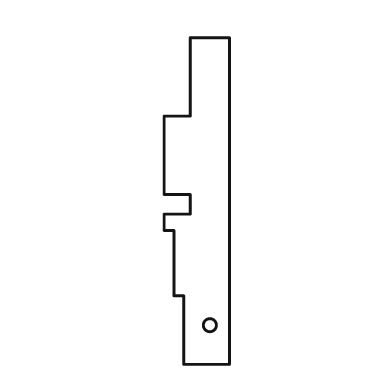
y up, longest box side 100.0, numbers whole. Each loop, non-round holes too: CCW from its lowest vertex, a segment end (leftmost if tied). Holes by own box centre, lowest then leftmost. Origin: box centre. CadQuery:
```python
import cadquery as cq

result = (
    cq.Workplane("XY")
    .moveTo(-4.0, -50.0)
    .lineTo(10.0, -50.0)
    .lineTo(10.0, 50.0)
    .lineTo(-2.0, 50.0)
    .lineTo(-2.0, 26.0)
    .lineTo(-10.0, 26.0)
    .lineTo(-10.0, 2.0)
    .lineTo(-2.0, 2.0)
    .lineTo(-2.0, -4.0)
    .lineTo(-10.0, -4.0)
    .lineTo(-10.0, -9.0)
    .lineTo(-7.0, -9.0)
    .lineTo(-7.0, -29.0)
    .lineTo(-4.0, -29.0)
    .close()
    .moveTo(4.0, -38.0)
    .circle(2.0)
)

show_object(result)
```